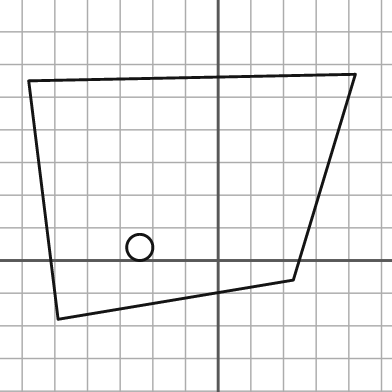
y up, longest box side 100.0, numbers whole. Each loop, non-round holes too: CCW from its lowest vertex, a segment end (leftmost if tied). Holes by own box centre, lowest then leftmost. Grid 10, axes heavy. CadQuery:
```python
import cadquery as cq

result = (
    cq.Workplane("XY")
    .moveTo(-49.0, -18.0)
    .lineTo(23.0, -6.0)
    .lineTo(42.0, 57.0)
    .lineTo(-58.0, 55.0)
    .close()
    .moveTo(-24.0, 4.0)
    .circle(4.0)
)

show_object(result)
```